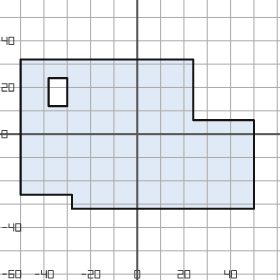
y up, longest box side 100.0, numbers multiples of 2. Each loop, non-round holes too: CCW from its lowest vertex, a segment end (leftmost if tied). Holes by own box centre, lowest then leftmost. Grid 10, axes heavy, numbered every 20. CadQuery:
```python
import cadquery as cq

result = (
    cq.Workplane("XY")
    .moveTo(-28.0, -32.0)
    .lineTo(50.0, -32.0)
    .lineTo(50.0, 6.0)
    .lineTo(24.0, 6.0)
    .lineTo(24.0, 32.0)
    .lineTo(-50.0, 32.0)
    .lineTo(-50.0, -26.0)
    .lineTo(-28.0, -26.0)
    .close()
    .moveTo(-38.0, 12.0)
    .lineTo(-30.0, 12.0)
    .lineTo(-30.0, 24.0)
    .lineTo(-38.0, 24.0)
    .close()
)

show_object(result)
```